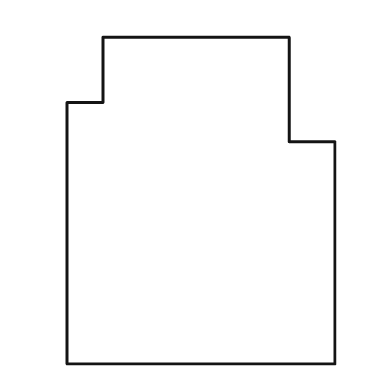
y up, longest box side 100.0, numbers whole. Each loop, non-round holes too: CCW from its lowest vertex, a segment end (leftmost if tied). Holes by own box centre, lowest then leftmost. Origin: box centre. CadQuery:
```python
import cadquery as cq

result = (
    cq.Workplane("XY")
    .moveTo(-41.0, -50.0)
    .lineTo(41.0, -50.0)
    .lineTo(41.0, 18.0)
    .lineTo(27.0, 18.0)
    .lineTo(27.0, 50.0)
    .lineTo(-30.0, 50.0)
    .lineTo(-30.0, 30.0)
    .lineTo(-41.0, 30.0)
    .close()
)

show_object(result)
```